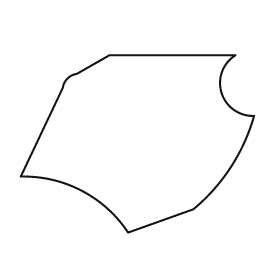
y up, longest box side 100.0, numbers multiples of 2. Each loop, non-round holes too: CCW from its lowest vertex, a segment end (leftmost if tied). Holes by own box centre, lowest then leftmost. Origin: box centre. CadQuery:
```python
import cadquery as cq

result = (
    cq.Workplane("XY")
    .moveTo(-4.0, -38.0)
    .lineTo(24.0, -28.0)
    .threePointArc((40.0, -10.0), (50.0, 12.0))
    .threePointArc((36.0, 22.0), (42.0, 38.0))
    .lineTo(-12.0, 38.0)
    .lineTo(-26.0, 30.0)
    .threePointArc((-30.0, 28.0), (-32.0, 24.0))
    .lineTo(-50.0, -14.0)
    .threePointArc((-24.0, -20.0), (-4.0, -38.0))
    .close()
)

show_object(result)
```